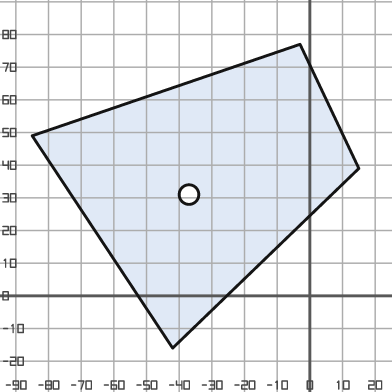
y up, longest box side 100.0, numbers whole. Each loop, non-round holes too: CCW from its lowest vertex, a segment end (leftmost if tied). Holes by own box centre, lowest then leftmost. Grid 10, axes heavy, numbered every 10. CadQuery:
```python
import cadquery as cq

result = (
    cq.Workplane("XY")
    .moveTo(-42.0, -16.0)
    .lineTo(15.0, 39.0)
    .lineTo(-3.0, 77.0)
    .lineTo(-85.0, 49.0)
    .close()
    .moveTo(-37.0, 31.0)
    .circle(3.0)
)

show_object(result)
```